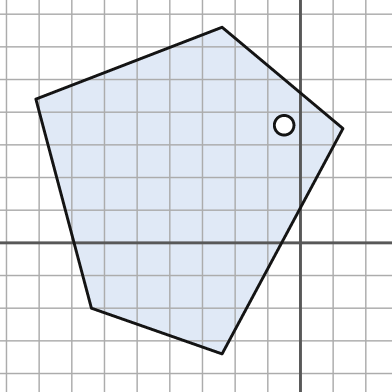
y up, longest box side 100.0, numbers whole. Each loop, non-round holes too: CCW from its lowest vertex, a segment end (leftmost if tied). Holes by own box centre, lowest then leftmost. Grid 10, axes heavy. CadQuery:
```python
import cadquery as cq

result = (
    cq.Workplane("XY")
    .moveTo(-24.0, -34.0)
    .lineTo(13.0, 35.0)
    .lineTo(-24.0, 66.0)
    .lineTo(-81.0, 44.0)
    .lineTo(-64.0, -20.0)
    .close()
    .moveTo(-5.0, 36.0)
    .circle(3.0)
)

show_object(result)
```